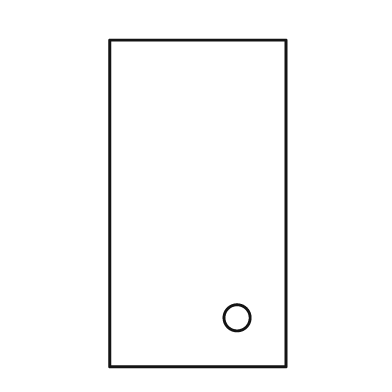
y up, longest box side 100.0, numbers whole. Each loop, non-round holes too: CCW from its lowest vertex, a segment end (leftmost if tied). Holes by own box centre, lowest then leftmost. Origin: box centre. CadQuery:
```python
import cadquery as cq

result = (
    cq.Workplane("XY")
    .moveTo(-27.0, -50.0)
    .lineTo(27.0, -50.0)
    .lineTo(27.0, 50.0)
    .lineTo(-27.0, 50.0)
    .close()
    .moveTo(12.0, -35.0)
    .circle(4.0)
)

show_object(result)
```